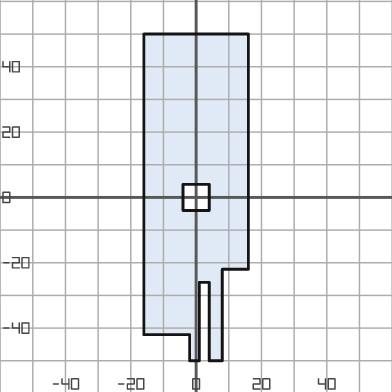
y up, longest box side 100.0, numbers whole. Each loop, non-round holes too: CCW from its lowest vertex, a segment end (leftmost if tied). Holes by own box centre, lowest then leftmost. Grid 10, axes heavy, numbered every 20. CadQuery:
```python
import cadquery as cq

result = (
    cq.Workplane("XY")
    .moveTo(-2.0, -50.0)
    .lineTo(1.0, -50.0)
    .lineTo(1.0, -26.0)
    .lineTo(4.0, -26.0)
    .lineTo(4.0, -50.0)
    .lineTo(8.0, -50.0)
    .lineTo(8.0, -22.0)
    .lineTo(16.0, -22.0)
    .lineTo(16.0, 50.0)
    .lineTo(-16.0, 50.0)
    .lineTo(-16.0, -42.0)
    .lineTo(-2.0, -42.0)
    .close()
    .moveTo(-4.0, -4.0)
    .lineTo(4.0, -4.0)
    .lineTo(4.0, 4.0)
    .lineTo(-4.0, 4.0)
    .close()
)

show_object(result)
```